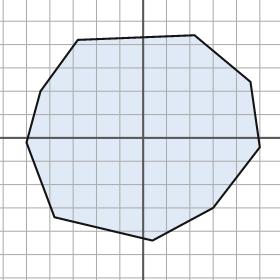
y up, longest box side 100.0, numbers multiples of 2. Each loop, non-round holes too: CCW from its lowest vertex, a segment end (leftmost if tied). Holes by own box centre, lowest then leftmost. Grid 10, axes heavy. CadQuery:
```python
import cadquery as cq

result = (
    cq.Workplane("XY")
    .moveTo(4.0, -44.0)
    .lineTo(30.0, -30.0)
    .lineTo(50.0, -4.0)
    .lineTo(46.0, 24.0)
    .lineTo(22.0, 44.0)
    .lineTo(-28.0, 42.0)
    .lineTo(-44.0, 20.0)
    .lineTo(-50.0, -2.0)
    .lineTo(-38.0, -34.0)
    .close()
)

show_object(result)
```